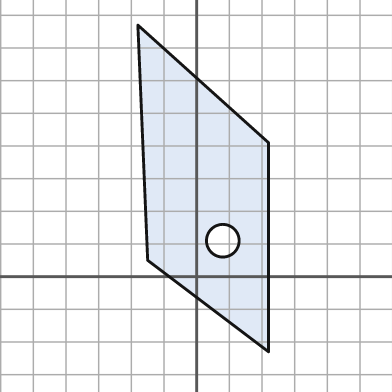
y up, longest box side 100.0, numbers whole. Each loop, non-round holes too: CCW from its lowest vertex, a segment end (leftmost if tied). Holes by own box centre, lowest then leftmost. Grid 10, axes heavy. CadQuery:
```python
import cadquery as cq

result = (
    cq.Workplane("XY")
    .moveTo(22.0, -23.0)
    .lineTo(22.0, 41.0)
    .lineTo(-18.0, 77.0)
    .lineTo(-15.0, 5.0)
    .close()
    .moveTo(8.0, 11.0)
    .circle(5.0)
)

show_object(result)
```